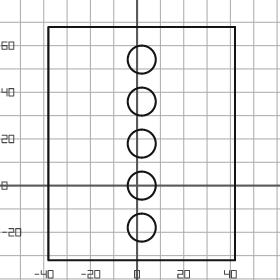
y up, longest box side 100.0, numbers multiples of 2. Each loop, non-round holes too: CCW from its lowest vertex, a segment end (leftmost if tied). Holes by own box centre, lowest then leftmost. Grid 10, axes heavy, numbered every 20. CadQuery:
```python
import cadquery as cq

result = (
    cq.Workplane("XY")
    .moveTo(-38.0, -32.0)
    .lineTo(42.0, -32.0)
    .lineTo(42.0, 68.0)
    .lineTo(-38.0, 68.0)
    .close()
    .moveTo(2.0, -18.0)
    .circle(6.0)
    .moveTo(2.0, 0.0)
    .circle(6.0)
    .moveTo(2.0, 18.0)
    .circle(6.0)
    .moveTo(2.0, 36.0)
    .circle(6.0)
    .moveTo(2.0, 54.0)
    .circle(6.0)
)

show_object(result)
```